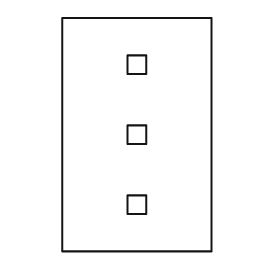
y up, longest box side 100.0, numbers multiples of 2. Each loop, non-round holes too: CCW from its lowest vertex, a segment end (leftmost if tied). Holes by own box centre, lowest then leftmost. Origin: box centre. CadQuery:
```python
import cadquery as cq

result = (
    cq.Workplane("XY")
    .moveTo(-32.0, -50.0)
    .lineTo(32.0, -50.0)
    .lineTo(32.0, 50.0)
    .lineTo(-32.0, 50.0)
    .close()
    .moveTo(-4.0, -34.0)
    .lineTo(4.0, -34.0)
    .lineTo(4.0, -26.0)
    .lineTo(-4.0, -26.0)
    .close()
    .moveTo(-4.0, -4.0)
    .lineTo(4.0, -4.0)
    .lineTo(4.0, 4.0)
    .lineTo(-4.0, 4.0)
    .close()
    .moveTo(-4.0, 26.0)
    .lineTo(4.0, 26.0)
    .lineTo(4.0, 34.0)
    .lineTo(-4.0, 34.0)
    .close()
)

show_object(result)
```